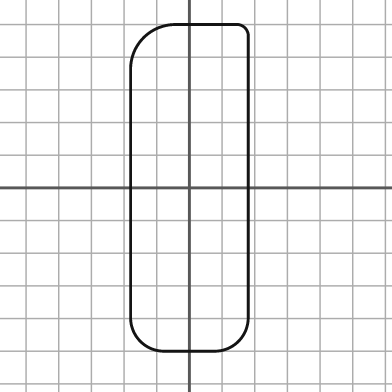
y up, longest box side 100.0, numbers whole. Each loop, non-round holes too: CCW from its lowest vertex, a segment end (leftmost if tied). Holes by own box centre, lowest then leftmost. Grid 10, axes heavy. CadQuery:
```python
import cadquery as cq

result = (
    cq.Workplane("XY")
    .moveTo(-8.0, -50.0)
    .lineTo(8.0, -50.0)
    .threePointArc((15.0, -47.0), (18.0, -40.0))
    .lineTo(18.0, 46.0)
    .threePointArc((17.0, 49.0), (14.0, 50.0))
    .lineTo(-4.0, 50.0)
    .threePointArc((-14.0, 46.0), (-18.0, 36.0))
    .lineTo(-18.0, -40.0)
    .threePointArc((-15.0, -47.0), (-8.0, -50.0))
    .close()
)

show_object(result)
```